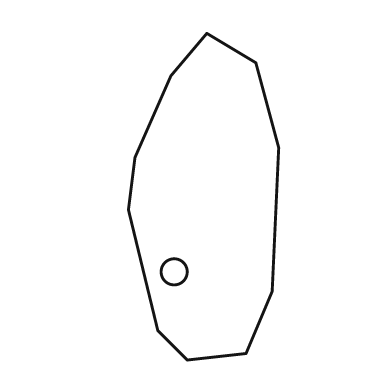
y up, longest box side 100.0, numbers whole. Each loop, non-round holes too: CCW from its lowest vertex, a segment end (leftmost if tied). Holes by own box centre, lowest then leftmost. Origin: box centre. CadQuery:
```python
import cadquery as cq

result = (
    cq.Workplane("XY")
    .moveTo(-5.0, -50.0)
    .lineTo(13.0, -48.0)
    .lineTo(21.0, -29.0)
    .lineTo(23.0, 15.0)
    .lineTo(16.0, 41.0)
    .lineTo(1.0, 50.0)
    .lineTo(-10.0, 37.0)
    .lineTo(-21.0, 12.0)
    .lineTo(-23.0, -4.0)
    .lineTo(-14.0, -41.0)
    .close()
    .moveTo(-9.0, -23.0)
    .circle(4.0)
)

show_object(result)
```